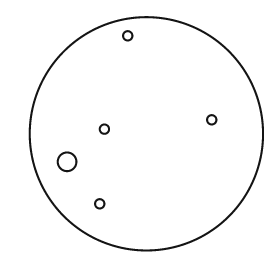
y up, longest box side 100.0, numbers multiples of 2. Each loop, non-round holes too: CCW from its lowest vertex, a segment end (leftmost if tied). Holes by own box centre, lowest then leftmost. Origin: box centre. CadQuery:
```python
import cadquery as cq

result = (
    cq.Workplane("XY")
    .moveTo(0.0, 0.0)
    .circle(50.0)
    .moveTo(-20.0, -30.0)
    .circle(2.0)
    .moveTo(-34.0, -12.0)
    .circle(4.0)
    .moveTo(-18.0, 2.0)
    .circle(2.0)
    .moveTo(28.0, 6.0)
    .circle(2.0)
    .moveTo(-8.0, 42.0)
    .circle(2.0)
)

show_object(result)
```